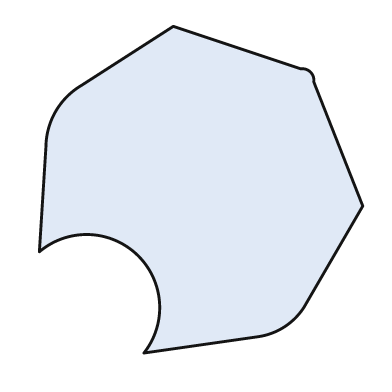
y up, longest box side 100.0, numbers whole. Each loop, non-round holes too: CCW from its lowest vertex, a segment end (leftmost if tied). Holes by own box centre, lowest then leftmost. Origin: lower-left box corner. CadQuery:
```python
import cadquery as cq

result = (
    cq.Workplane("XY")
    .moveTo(32.0, 0.0)
    .lineTo(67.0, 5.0)
    .threePointArc((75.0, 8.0), (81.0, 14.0))
    .lineTo(99.0, 45.0)
    .lineTo(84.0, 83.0)
    .threePointArc((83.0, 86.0), (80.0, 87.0))
    .lineTo(41.0, 100.0)
    .lineTo(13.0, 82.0)
    .threePointArc((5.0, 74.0), (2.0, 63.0))
    .lineTo(0.0, 31.0)
    .threePointArc((30.0, 30.0), (32.0, 0.0))
    .close()
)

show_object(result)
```